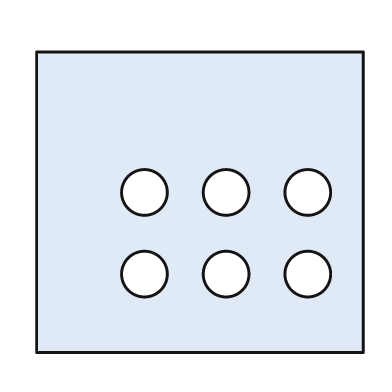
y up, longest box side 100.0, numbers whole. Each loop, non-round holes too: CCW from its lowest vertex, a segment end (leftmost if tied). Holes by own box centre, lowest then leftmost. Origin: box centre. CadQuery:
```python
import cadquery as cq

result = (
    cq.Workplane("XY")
    .moveTo(-50.0, -46.0)
    .lineTo(50.0, -46.0)
    .lineTo(50.0, 46.0)
    .lineTo(-50.0, 46.0)
    .close()
    .moveTo(-17.0, -22.0)
    .circle(7.0)
    .moveTo(8.0, -22.0)
    .circle(7.0)
    .moveTo(33.0, -22.0)
    .circle(7.0)
    .moveTo(-17.0, 3.0)
    .circle(7.0)
    .moveTo(8.0, 3.0)
    .circle(7.0)
    .moveTo(33.0, 3.0)
    .circle(7.0)
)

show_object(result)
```